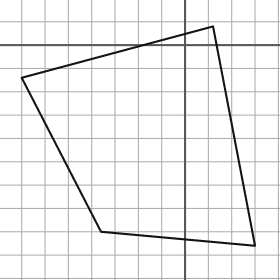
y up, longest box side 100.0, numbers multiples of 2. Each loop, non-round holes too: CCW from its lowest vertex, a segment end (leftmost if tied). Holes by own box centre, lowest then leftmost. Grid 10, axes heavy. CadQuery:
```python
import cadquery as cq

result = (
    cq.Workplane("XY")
    .moveTo(30.0, -86.0)
    .lineTo(12.0, 8.0)
    .lineTo(-70.0, -14.0)
    .lineTo(-36.0, -80.0)
    .close()
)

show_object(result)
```